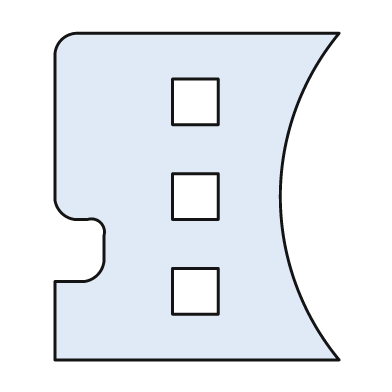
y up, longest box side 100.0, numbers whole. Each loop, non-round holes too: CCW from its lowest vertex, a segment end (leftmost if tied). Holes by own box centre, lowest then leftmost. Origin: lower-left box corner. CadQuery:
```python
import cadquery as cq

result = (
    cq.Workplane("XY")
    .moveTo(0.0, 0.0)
    .lineTo(87.0, 0.0)
    .threePointArc((69.0, 50.0), (87.0, 100.0))
    .lineTo(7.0, 100.0)
    .threePointArc((2.0, 98.0), (0.0, 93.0))
    .lineTo(0.0, 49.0)
    .threePointArc((2.0, 45.0), (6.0, 43.0))
    .lineTo(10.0, 43.0)
    .threePointArc((14.0, 42.0), (15.0, 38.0))
    .lineTo(15.0, 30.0)
    .threePointArc((13.0, 26.0), (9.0, 24.0))
    .lineTo(0.0, 24.0)
    .close()
    .moveTo(36.0, 14.0)
    .lineTo(50.0, 14.0)
    .lineTo(50.0, 28.0)
    .lineTo(36.0, 28.0)
    .close()
    .moveTo(36.0, 43.0)
    .lineTo(50.0, 43.0)
    .lineTo(50.0, 57.0)
    .lineTo(36.0, 57.0)
    .close()
    .moveTo(36.0, 72.0)
    .lineTo(50.0, 72.0)
    .lineTo(50.0, 86.0)
    .lineTo(36.0, 86.0)
    .close()
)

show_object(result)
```